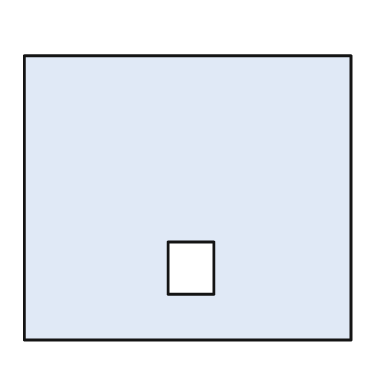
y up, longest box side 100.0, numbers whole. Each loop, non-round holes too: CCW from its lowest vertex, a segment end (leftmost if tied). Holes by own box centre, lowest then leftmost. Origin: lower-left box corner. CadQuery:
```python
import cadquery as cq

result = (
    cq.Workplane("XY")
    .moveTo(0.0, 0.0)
    .lineTo(100.0, 0.0)
    .lineTo(100.0, 87.0)
    .lineTo(0.0, 87.0)
    .close()
    .moveTo(44.0, 14.0)
    .lineTo(58.0, 14.0)
    .lineTo(58.0, 30.0)
    .lineTo(44.0, 30.0)
    .close()
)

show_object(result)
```